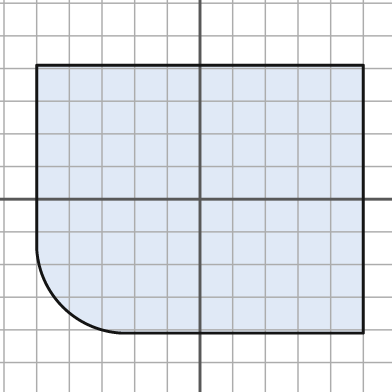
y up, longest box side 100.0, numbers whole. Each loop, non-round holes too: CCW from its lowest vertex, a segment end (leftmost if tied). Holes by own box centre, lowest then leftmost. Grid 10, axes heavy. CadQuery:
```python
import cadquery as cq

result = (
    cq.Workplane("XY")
    .moveTo(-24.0, -41.0)
    .lineTo(50.0, -41.0)
    .lineTo(50.0, 41.0)
    .lineTo(-50.0, 41.0)
    .lineTo(-50.0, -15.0)
    .threePointArc((-42.0, -33.0), (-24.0, -41.0))
    .close()
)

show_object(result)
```